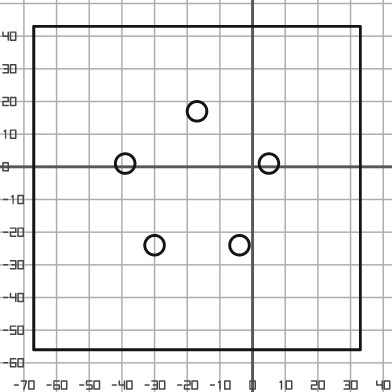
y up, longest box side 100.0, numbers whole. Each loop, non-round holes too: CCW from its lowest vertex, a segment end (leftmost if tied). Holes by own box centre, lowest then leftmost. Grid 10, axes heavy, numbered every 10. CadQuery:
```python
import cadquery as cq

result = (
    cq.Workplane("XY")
    .moveTo(-67.0, -56.0)
    .lineTo(33.0, -56.0)
    .lineTo(33.0, 43.0)
    .lineTo(-67.0, 43.0)
    .close()
    .moveTo(-30.0, -24.0)
    .circle(3.0)
    .moveTo(-4.0, -24.0)
    .circle(3.0)
    .moveTo(-39.0, 1.0)
    .circle(3.0)
    .moveTo(5.0, 1.0)
    .circle(3.0)
    .moveTo(-17.0, 17.0)
    .circle(3.0)
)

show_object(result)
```